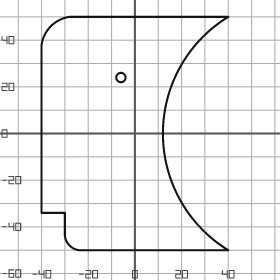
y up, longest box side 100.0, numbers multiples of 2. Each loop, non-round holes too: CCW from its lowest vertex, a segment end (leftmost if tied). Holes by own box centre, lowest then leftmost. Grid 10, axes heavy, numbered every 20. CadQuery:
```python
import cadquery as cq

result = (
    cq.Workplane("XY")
    .moveTo(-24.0, -50.0)
    .lineTo(40.0, -50.0)
    .threePointArc((12.0, 0.0), (40.0, 50.0))
    .lineTo(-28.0, 50.0)
    .threePointArc((-36.0, 46.0), (-40.0, 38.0))
    .lineTo(-40.0, -34.0)
    .lineTo(-30.0, -34.0)
    .lineTo(-30.0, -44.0)
    .threePointArc((-28.0, -48.0), (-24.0, -50.0))
    .close()
    .moveTo(-6.0, 24.0)
    .circle(2.0)
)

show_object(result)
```